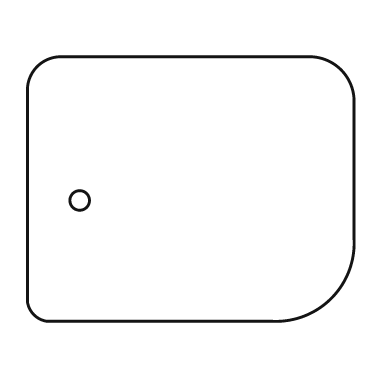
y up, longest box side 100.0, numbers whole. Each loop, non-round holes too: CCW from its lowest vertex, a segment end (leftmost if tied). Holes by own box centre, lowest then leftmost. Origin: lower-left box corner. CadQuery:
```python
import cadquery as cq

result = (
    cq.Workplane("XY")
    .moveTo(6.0, 0.0)
    .lineTo(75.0, 0.0)
    .threePointArc((93.0, 7.0), (100.0, 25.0))
    .lineTo(100.0, 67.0)
    .threePointArc((96.0, 77.0), (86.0, 81.0))
    .lineTo(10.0, 81.0)
    .threePointArc((3.0, 78.0), (0.0, 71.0))
    .lineTo(0.0, 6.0)
    .threePointArc((2.0, 2.0), (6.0, 0.0))
    .close()
    .moveTo(16.0, 37.0)
    .circle(3.0)
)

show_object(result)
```